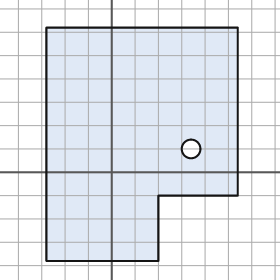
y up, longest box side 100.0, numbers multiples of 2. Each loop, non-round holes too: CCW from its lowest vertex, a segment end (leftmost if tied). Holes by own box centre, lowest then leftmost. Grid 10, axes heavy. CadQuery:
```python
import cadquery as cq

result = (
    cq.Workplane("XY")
    .moveTo(-28.0, -38.0)
    .lineTo(20.0, -38.0)
    .lineTo(20.0, -10.0)
    .lineTo(54.0, -10.0)
    .lineTo(54.0, 62.0)
    .lineTo(-28.0, 62.0)
    .close()
    .moveTo(34.0, 10.0)
    .circle(4.0)
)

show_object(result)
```